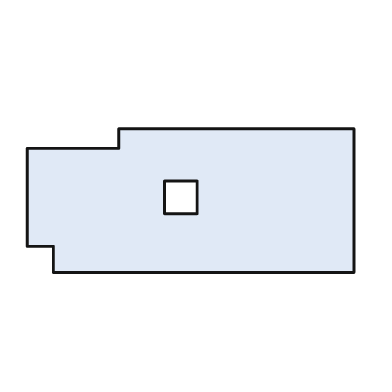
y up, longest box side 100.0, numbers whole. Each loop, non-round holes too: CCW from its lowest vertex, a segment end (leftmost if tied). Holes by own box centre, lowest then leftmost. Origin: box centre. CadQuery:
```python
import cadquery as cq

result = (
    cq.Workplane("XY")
    .moveTo(-42.0, -22.0)
    .lineTo(50.0, -22.0)
    .lineTo(50.0, 22.0)
    .lineTo(-22.0, 22.0)
    .lineTo(-22.0, 16.0)
    .lineTo(-50.0, 16.0)
    .lineTo(-50.0, -14.0)
    .lineTo(-42.0, -14.0)
    .close()
    .moveTo(-8.0, -4.0)
    .lineTo(2.0, -4.0)
    .lineTo(2.0, 6.0)
    .lineTo(-8.0, 6.0)
    .close()
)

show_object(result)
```